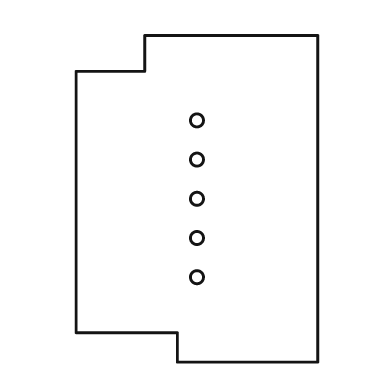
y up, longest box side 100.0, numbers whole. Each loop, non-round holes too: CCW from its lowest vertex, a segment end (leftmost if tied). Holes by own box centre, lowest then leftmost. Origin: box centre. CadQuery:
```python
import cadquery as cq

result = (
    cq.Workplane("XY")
    .moveTo(-6.0, -50.0)
    .lineTo(37.0, -50.0)
    .lineTo(37.0, 50.0)
    .lineTo(-16.0, 50.0)
    .lineTo(-16.0, 39.0)
    .lineTo(-37.0, 39.0)
    .lineTo(-37.0, -41.0)
    .lineTo(-6.0, -41.0)
    .close()
    .moveTo(0.0, -24.0)
    .circle(2.0)
    .moveTo(0.0, -12.0)
    .circle(2.0)
    .moveTo(0.0, 0.0)
    .circle(2.0)
    .moveTo(0.0, 12.0)
    .circle(2.0)
    .moveTo(0.0, 24.0)
    .circle(2.0)
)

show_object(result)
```